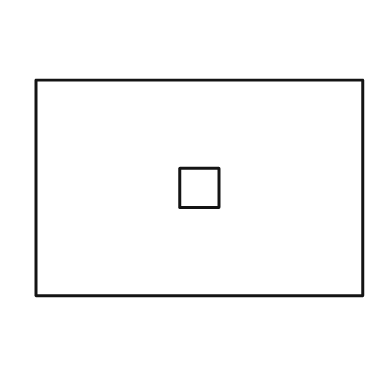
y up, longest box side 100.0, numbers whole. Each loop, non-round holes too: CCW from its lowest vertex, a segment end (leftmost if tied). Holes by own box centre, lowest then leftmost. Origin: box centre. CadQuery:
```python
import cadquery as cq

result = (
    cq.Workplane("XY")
    .moveTo(-50.0, -33.0)
    .lineTo(50.0, -33.0)
    .lineTo(50.0, 33.0)
    .lineTo(-50.0, 33.0)
    .close()
    .moveTo(-6.0, -6.0)
    .lineTo(6.0, -6.0)
    .lineTo(6.0, 6.0)
    .lineTo(-6.0, 6.0)
    .close()
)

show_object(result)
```